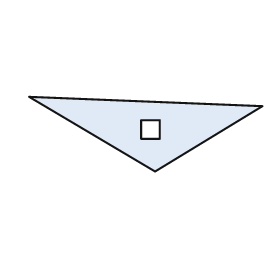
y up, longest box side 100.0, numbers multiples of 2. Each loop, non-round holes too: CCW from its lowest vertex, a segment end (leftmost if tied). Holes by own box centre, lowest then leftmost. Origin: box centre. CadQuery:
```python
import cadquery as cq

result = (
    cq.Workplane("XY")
    .moveTo(4.0, -16.0)
    .lineTo(50.0, 12.0)
    .lineTo(-50.0, 16.0)
    .close()
    .moveTo(-2.0, -2.0)
    .lineTo(6.0, -2.0)
    .lineTo(6.0, 6.0)
    .lineTo(-2.0, 6.0)
    .close()
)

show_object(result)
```